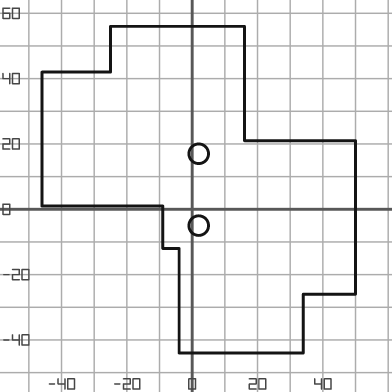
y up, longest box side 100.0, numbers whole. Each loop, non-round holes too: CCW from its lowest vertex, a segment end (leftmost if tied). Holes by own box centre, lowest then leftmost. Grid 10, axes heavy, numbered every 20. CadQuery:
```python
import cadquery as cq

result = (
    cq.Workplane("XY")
    .moveTo(-4.0, -44.0)
    .lineTo(34.0, -44.0)
    .lineTo(34.0, -26.0)
    .lineTo(50.0, -26.0)
    .lineTo(50.0, 21.0)
    .lineTo(16.0, 21.0)
    .lineTo(16.0, 56.0)
    .lineTo(-25.0, 56.0)
    .lineTo(-25.0, 42.0)
    .lineTo(-46.0, 42.0)
    .lineTo(-46.0, 1.0)
    .lineTo(-9.0, 1.0)
    .lineTo(-9.0, -12.0)
    .lineTo(-4.0, -12.0)
    .close()
    .moveTo(2.0, -5.0)
    .circle(3.0)
    .moveTo(2.0, 17.0)
    .circle(3.0)
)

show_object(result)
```